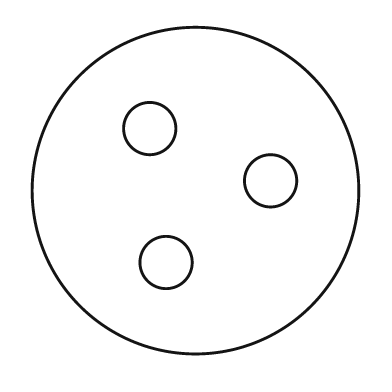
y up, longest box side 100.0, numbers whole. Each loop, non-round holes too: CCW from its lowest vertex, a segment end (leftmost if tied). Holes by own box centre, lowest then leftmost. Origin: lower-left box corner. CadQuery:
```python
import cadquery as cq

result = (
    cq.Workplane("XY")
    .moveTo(50.0, 50.0)
    .circle(50.0)
    .moveTo(41.0, 28.0)
    .circle(8.0)
    .moveTo(73.0, 53.0)
    .circle(8.0)
    .moveTo(36.0, 69.0)
    .circle(8.0)
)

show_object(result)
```